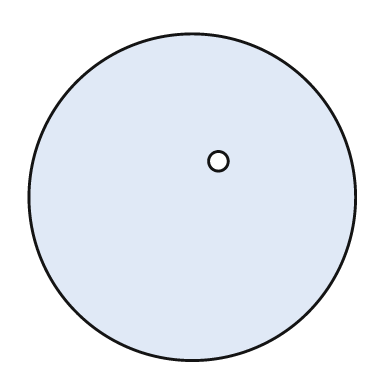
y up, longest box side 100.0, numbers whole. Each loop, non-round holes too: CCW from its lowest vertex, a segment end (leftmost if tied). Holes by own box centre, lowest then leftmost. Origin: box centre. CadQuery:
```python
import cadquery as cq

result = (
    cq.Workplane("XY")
    .moveTo(0.0, 0.0)
    .circle(50.0)
    .moveTo(8.0, 11.0)
    .circle(3.0)
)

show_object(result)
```